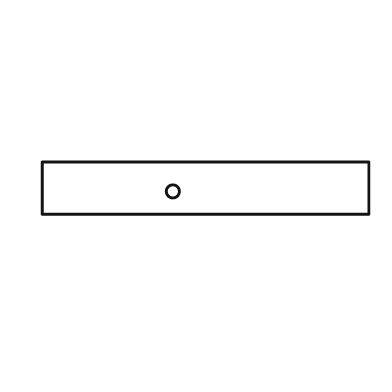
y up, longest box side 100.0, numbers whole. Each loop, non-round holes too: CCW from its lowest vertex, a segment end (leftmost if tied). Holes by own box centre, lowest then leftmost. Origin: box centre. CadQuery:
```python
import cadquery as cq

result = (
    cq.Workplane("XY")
    .moveTo(-50.0, -8.0)
    .lineTo(50.0, -8.0)
    .lineTo(50.0, 8.0)
    .lineTo(-50.0, 8.0)
    .close()
    .moveTo(-10.0, -1.0)
    .circle(2.0)
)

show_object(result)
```